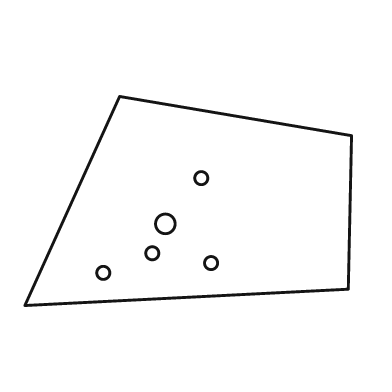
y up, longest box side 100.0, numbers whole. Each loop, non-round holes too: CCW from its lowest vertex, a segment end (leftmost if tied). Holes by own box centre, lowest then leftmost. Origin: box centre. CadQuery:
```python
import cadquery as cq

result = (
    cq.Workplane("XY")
    .moveTo(-50.0, -32.0)
    .lineTo(49.0, -27.0)
    .lineTo(50.0, 20.0)
    .lineTo(-21.0, 32.0)
    .close()
    .moveTo(-26.0, -22.0)
    .circle(2.0)
    .moveTo(7.0, -19.0)
    .circle(2.0)
    .moveTo(-11.0, -16.0)
    .circle(2.0)
    .moveTo(-7.0, -7.0)
    .circle(3.0)
    .moveTo(4.0, 7.0)
    .circle(2.0)
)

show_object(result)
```